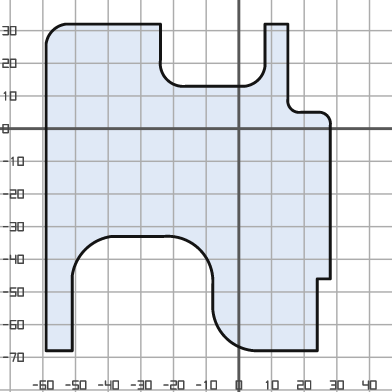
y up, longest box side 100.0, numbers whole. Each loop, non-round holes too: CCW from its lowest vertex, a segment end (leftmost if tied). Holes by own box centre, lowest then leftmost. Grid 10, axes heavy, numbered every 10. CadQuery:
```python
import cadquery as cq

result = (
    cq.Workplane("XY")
    .moveTo(-59.0, -68.0)
    .lineTo(-51.0, -68.0)
    .lineTo(-51.0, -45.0)
    .threePointArc((-47.0, -37.0), (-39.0, -33.0))
    .lineTo(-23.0, -33.0)
    .threePointArc((-12.0, -37.0), (-8.0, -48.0))
    .lineTo(-8.0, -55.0)
    .threePointArc((-4.0, -64.0), (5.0, -68.0))
    .lineTo(24.0, -68.0)
    .lineTo(24.0, -46.0)
    .lineTo(28.0, -46.0)
    .lineTo(28.0, 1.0)
    .threePointArc((27.0, 4.0), (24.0, 5.0))
    .lineTo(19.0, 5.0)
    .threePointArc((16.0, 6.0), (15.0, 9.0))
    .lineTo(15.0, 32.0)
    .lineTo(8.0, 32.0)
    .lineTo(8.0, 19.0)
    .threePointArc((6.0, 15.0), (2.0, 13.0))
    .lineTo(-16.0, 13.0)
    .threePointArc((-22.0, 15.0), (-24.0, 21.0))
    .lineTo(-24.0, 32.0)
    .lineTo(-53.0, 32.0)
    .threePointArc((-57.0, 30.0), (-59.0, 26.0))
    .close()
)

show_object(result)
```